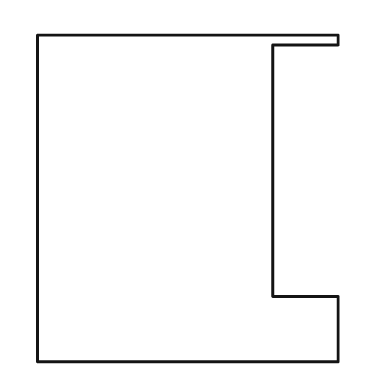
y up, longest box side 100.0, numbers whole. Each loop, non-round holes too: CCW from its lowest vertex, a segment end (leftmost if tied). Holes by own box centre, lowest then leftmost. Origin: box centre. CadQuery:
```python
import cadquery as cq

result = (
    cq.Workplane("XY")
    .moveTo(-46.0, -50.0)
    .lineTo(46.0, -50.0)
    .lineTo(46.0, -30.0)
    .lineTo(26.0, -30.0)
    .lineTo(26.0, 47.0)
    .lineTo(46.0, 47.0)
    .lineTo(46.0, 50.0)
    .lineTo(-46.0, 50.0)
    .close()
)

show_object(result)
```